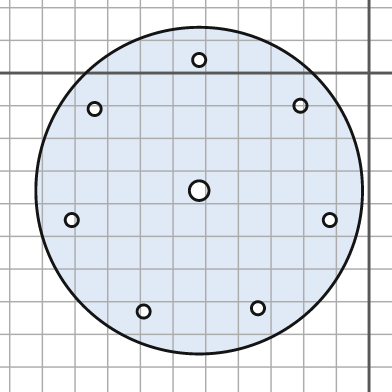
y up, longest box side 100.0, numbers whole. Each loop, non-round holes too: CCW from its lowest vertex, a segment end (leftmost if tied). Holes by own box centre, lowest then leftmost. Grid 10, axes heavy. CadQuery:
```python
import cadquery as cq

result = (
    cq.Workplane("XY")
    .moveTo(-52.0, -36.0)
    .circle(50.0)
    .moveTo(-69.0, -73.0)
    .circle(2.0)
    .moveTo(-34.0, -72.0)
    .circle(2.0)
    .moveTo(-91.0, -45.0)
    .circle(2.0)
    .moveTo(-12.0, -45.0)
    .circle(2.0)
    .moveTo(-52.0, -36.0)
    .circle(3.0)
    .moveTo(-84.0, -11.0)
    .circle(2.0)
    .moveTo(-21.0, -10.0)
    .circle(2.0)
    .moveTo(-52.0, 4.0)
    .circle(2.0)
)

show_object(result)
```